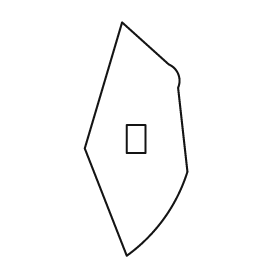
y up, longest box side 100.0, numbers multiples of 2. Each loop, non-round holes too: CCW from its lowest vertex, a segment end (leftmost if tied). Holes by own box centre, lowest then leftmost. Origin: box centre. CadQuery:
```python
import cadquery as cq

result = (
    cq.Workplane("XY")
    .moveTo(-4.0, -50.0)
    .threePointArc((12.0, -34.0), (22.0, -14.0))
    .lineTo(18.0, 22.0)
    .threePointArc((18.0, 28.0), (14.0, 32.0))
    .lineTo(-6.0, 50.0)
    .lineTo(-22.0, -4.0)
    .close()
    .moveTo(-4.0, -6.0)
    .lineTo(4.0, -6.0)
    .lineTo(4.0, 6.0)
    .lineTo(-4.0, 6.0)
    .close()
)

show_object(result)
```